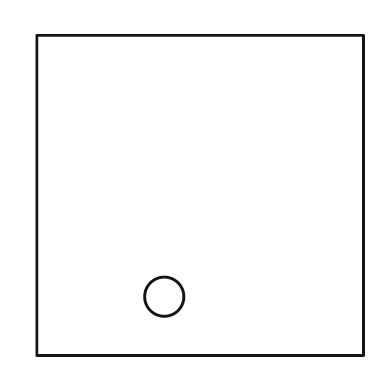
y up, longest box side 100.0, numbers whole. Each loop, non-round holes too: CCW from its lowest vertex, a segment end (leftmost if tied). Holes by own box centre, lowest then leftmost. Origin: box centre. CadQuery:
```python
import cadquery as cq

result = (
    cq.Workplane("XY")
    .moveTo(-50.0, -49.0)
    .lineTo(50.0, -49.0)
    .lineTo(50.0, 49.0)
    .lineTo(-50.0, 49.0)
    .close()
    .moveTo(-11.0, -31.0)
    .circle(6.0)
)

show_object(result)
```